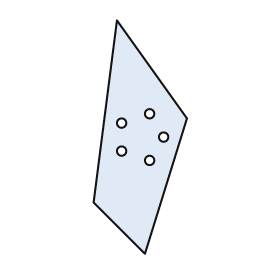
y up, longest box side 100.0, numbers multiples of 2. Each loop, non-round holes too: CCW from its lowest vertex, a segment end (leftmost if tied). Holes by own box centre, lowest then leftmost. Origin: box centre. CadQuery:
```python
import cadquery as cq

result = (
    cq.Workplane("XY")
    .moveTo(2.0, -50.0)
    .lineTo(20.0, 8.0)
    .lineTo(-10.0, 50.0)
    .lineTo(-20.0, -28.0)
    .close()
    .moveTo(4.0, -10.0)
    .circle(2.0)
    .moveTo(-8.0, -6.0)
    .circle(2.0)
    .moveTo(10.0, 0.0)
    .circle(2.0)
    .moveTo(-8.0, 6.0)
    .circle(2.0)
    .moveTo(4.0, 10.0)
    .circle(2.0)
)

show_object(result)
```